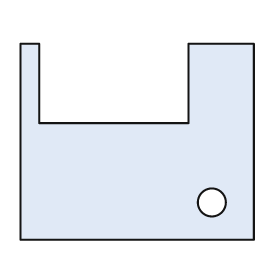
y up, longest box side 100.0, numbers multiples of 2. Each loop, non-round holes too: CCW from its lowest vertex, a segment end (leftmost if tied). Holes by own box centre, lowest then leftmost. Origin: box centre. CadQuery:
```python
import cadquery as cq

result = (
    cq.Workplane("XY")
    .moveTo(-50.0, -42.0)
    .lineTo(50.0, -42.0)
    .lineTo(50.0, 42.0)
    .lineTo(22.0, 42.0)
    .lineTo(22.0, 8.0)
    .lineTo(-42.0, 8.0)
    .lineTo(-42.0, 42.0)
    .lineTo(-50.0, 42.0)
    .close()
    .moveTo(32.0, -26.0)
    .circle(6.0)
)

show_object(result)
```